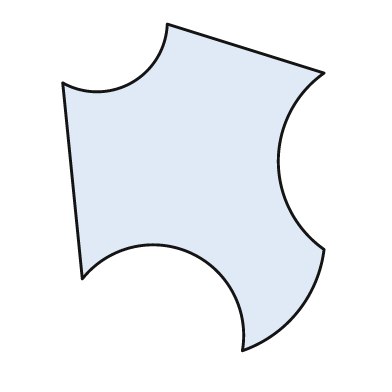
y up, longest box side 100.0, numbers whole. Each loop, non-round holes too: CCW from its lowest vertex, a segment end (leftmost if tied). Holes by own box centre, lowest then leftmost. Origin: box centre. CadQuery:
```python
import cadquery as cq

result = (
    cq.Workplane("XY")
    .moveTo(15.0, -50.0)
    .threePointArc((32.0, -38.0), (40.0, -19.0))
    .threePointArc((26.0, 8.0), (40.0, 35.0))
    .lineTo(-8.0, 50.0)
    .threePointArc((-19.0, 32.0), (-40.0, 32.0))
    .lineTo(-34.0, -28.0)
    .threePointArc((-1.0, -20.0), (15.0, -50.0))
    .close()
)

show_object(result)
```